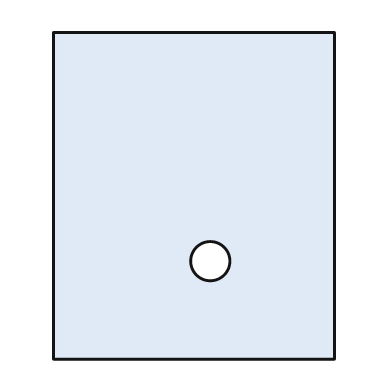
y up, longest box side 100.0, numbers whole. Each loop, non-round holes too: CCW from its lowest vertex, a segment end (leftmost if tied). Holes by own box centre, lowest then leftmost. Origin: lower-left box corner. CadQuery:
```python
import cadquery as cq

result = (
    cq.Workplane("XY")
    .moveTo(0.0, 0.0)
    .lineTo(86.0, 0.0)
    .lineTo(86.0, 100.0)
    .lineTo(0.0, 100.0)
    .close()
    .moveTo(48.0, 30.0)
    .circle(6.0)
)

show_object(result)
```